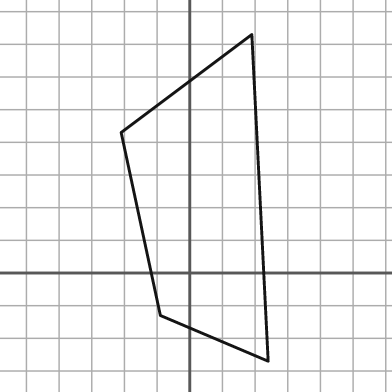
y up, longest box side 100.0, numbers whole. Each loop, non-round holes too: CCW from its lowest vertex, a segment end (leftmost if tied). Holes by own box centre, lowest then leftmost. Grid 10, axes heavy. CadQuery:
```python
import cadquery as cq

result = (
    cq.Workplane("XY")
    .moveTo(24.0, -27.0)
    .lineTo(19.0, 73.0)
    .lineTo(-21.0, 43.0)
    .lineTo(-9.0, -13.0)
    .close()
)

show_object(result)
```